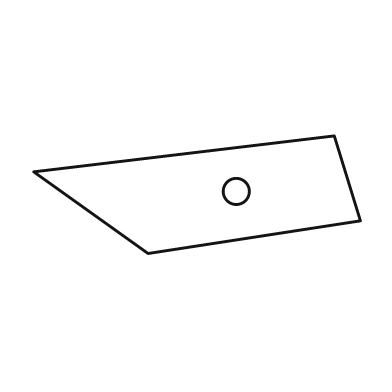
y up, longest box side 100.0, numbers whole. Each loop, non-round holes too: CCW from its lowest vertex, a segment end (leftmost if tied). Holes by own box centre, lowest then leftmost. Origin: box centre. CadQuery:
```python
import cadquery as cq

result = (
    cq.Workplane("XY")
    .moveTo(-15.0, -18.0)
    .lineTo(50.0, -8.0)
    .lineTo(42.0, 18.0)
    .lineTo(-50.0, 7.0)
    .close()
    .moveTo(12.0, 1.0)
    .circle(4.0)
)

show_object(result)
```